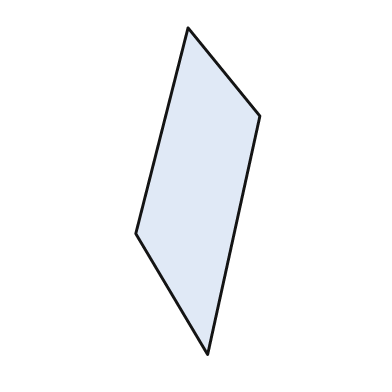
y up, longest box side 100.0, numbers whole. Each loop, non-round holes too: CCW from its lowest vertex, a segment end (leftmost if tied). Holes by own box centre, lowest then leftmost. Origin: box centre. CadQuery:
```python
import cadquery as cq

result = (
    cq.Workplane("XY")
    .moveTo(3.0, -50.0)
    .lineTo(19.0, 23.0)
    .lineTo(-3.0, 50.0)
    .lineTo(-19.0, -13.0)
    .close()
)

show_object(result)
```